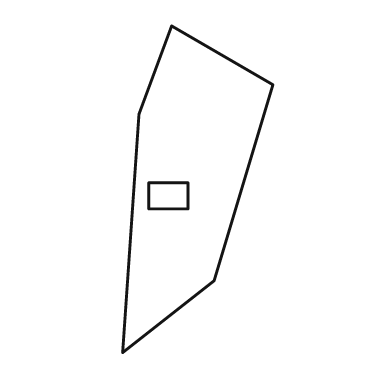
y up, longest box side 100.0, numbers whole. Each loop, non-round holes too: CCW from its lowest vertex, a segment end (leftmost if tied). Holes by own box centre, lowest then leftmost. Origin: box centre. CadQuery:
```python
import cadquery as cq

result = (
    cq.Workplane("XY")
    .moveTo(-23.0, -50.0)
    .lineTo(5.0, -28.0)
    .lineTo(23.0, 32.0)
    .lineTo(-8.0, 50.0)
    .lineTo(-18.0, 23.0)
    .close()
    .moveTo(-15.0, -6.0)
    .lineTo(-3.0, -6.0)
    .lineTo(-3.0, 2.0)
    .lineTo(-15.0, 2.0)
    .close()
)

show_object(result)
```